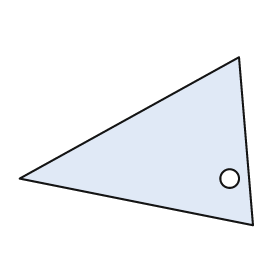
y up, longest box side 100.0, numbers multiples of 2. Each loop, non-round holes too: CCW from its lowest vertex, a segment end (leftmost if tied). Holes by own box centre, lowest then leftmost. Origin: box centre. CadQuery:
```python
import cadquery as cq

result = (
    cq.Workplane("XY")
    .moveTo(50.0, -36.0)
    .lineTo(44.0, 36.0)
    .lineTo(-50.0, -16.0)
    .close()
    .moveTo(40.0, -16.0)
    .circle(4.0)
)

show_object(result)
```